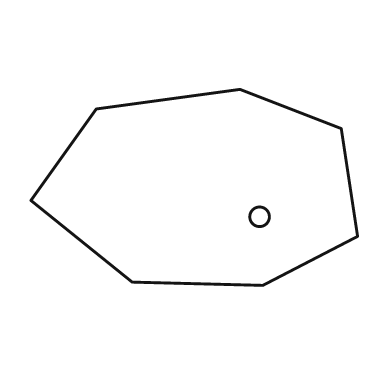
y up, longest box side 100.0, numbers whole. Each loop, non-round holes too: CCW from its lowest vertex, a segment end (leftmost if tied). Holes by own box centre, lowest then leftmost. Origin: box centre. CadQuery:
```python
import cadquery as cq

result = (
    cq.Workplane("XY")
    .moveTo(21.0, -30.0)
    .lineTo(50.0, -15.0)
    .lineTo(45.0, 18.0)
    .lineTo(14.0, 30.0)
    .lineTo(-30.0, 24.0)
    .lineTo(-50.0, -4.0)
    .lineTo(-19.0, -29.0)
    .close()
    .moveTo(20.0, -9.0)
    .circle(3.0)
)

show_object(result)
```